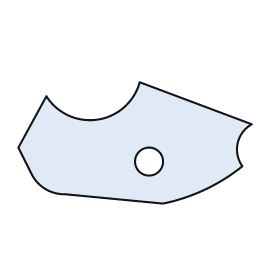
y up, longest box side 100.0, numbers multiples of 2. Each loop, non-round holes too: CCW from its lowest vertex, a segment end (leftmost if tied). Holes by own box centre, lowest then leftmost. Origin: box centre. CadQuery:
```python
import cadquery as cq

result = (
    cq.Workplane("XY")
    .moveTo(12.0, -26.0)
    .threePointArc((30.0, -20.0), (46.0, -10.0))
    .threePointArc((44.0, 0.0), (50.0, 8.0))
    .lineTo(2.0, 26.0)
    .threePointArc((-16.0, 10.0), (-38.0, 20.0))
    .lineTo(-50.0, -2.0)
    .lineTo(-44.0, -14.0)
    .threePointArc((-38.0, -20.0), (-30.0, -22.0))
    .close()
    .moveTo(6.0, -8.0)
    .circle(6.0)
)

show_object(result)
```